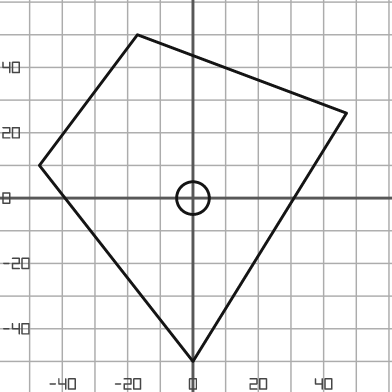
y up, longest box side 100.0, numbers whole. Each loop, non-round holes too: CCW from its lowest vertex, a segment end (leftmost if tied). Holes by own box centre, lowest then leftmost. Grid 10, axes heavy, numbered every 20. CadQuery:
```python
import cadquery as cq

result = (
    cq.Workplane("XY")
    .moveTo(0.0, -50.0)
    .lineTo(47.0, 26.0)
    .lineTo(-17.0, 50.0)
    .lineTo(-47.0, 10.0)
    .close()
    .moveTo(0.0, 0.0)
    .circle(5.0)
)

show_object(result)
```